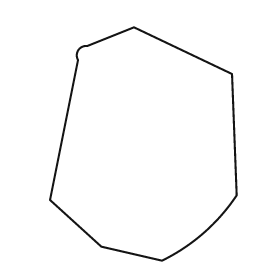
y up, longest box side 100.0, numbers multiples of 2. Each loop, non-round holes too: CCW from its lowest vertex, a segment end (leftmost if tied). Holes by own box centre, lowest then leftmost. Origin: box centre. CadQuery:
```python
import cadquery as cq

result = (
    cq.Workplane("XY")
    .moveTo(8.0, -50.0)
    .threePointArc((26.0, -38.0), (40.0, -22.0))
    .lineTo(38.0, 30.0)
    .lineTo(-4.0, 50.0)
    .lineTo(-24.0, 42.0)
    .threePointArc((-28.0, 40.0), (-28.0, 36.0))
    .lineTo(-40.0, -24.0)
    .lineTo(-18.0, -44.0)
    .close()
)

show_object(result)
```